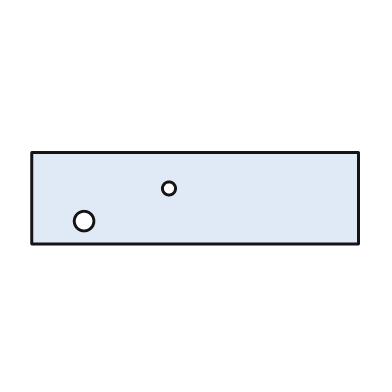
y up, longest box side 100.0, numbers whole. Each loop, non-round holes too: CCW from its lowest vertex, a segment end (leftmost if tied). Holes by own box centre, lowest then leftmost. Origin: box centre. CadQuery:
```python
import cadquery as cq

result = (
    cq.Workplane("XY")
    .moveTo(-50.0, -14.0)
    .lineTo(50.0, -14.0)
    .lineTo(50.0, 14.0)
    .lineTo(-50.0, 14.0)
    .close()
    .moveTo(-34.0, -7.0)
    .circle(3.0)
    .moveTo(-8.0, 3.0)
    .circle(2.0)
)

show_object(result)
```